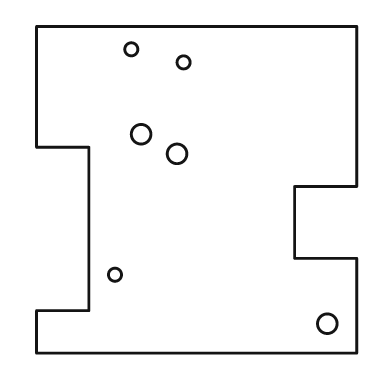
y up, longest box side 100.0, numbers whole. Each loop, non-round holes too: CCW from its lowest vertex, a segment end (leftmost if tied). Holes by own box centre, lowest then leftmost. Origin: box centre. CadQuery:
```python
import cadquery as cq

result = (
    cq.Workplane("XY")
    .moveTo(-49.0, -50.0)
    .lineTo(49.0, -50.0)
    .lineTo(49.0, -21.0)
    .lineTo(30.0, -21.0)
    .lineTo(30.0, 1.0)
    .lineTo(49.0, 1.0)
    .lineTo(49.0, 50.0)
    .lineTo(-49.0, 50.0)
    .lineTo(-49.0, 13.0)
    .lineTo(-33.0, 13.0)
    .lineTo(-33.0, -37.0)
    .lineTo(-49.0, -37.0)
    .close()
    .moveTo(40.0, -41.0)
    .circle(3.0)
    .moveTo(-25.0, -26.0)
    .circle(2.0)
    .moveTo(-6.0, 11.0)
    .circle(3.0)
    .moveTo(-17.0, 17.0)
    .circle(3.0)
    .moveTo(-4.0, 39.0)
    .circle(2.0)
    .moveTo(-20.0, 43.0)
    .circle(2.0)
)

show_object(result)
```